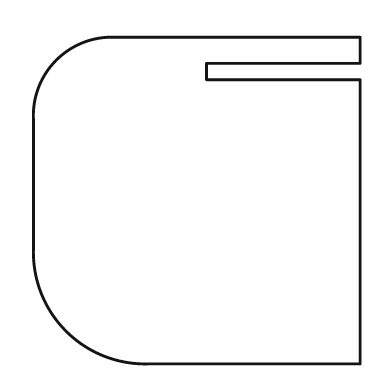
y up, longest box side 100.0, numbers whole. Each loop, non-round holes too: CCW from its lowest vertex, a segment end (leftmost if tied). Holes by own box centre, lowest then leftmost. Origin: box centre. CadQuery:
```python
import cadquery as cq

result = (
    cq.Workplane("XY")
    .moveTo(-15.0, -50.0)
    .lineTo(50.0, -50.0)
    .lineTo(50.0, 37.0)
    .lineTo(3.0, 37.0)
    .lineTo(3.0, 42.0)
    .lineTo(50.0, 42.0)
    .lineTo(50.0, 50.0)
    .lineTo(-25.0, 50.0)
    .threePointArc((-43.0, 43.0), (-50.0, 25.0))
    .lineTo(-50.0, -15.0)
    .threePointArc((-40.0, -40.0), (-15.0, -50.0))
    .close()
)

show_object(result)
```